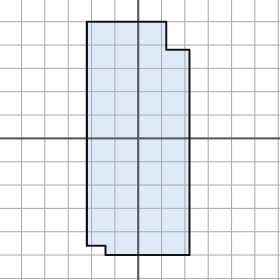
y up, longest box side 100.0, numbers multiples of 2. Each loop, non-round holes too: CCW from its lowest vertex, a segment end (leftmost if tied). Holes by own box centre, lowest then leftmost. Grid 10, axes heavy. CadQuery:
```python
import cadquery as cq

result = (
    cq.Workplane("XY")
    .moveTo(-14.0, -50.0)
    .lineTo(22.0, -50.0)
    .lineTo(22.0, 38.0)
    .lineTo(12.0, 38.0)
    .lineTo(12.0, 50.0)
    .lineTo(-22.0, 50.0)
    .lineTo(-22.0, -46.0)
    .lineTo(-14.0, -46.0)
    .close()
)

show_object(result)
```